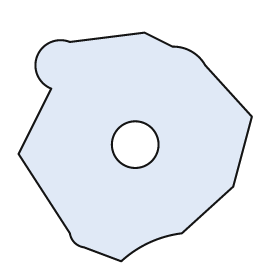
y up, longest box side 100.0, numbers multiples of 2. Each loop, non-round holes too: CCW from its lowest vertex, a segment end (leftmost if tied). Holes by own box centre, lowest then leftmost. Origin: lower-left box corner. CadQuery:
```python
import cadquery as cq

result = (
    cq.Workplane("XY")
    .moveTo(44.0, 0.0)
    .threePointArc((56.0, 8.0), (70.0, 12.0))
    .lineTo(92.0, 32.0)
    .lineTo(100.0, 62.0)
    .lineTo(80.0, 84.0)
    .threePointArc((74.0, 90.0), (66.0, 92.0))
    .lineTo(54.0, 98.0)
    .lineTo(22.0, 94.0)
    .threePointArc((8.0, 88.0), (14.0, 74.0))
    .lineTo(0.0, 46.0)
    .lineTo(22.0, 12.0)
    .threePointArc((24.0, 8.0), (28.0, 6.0))
    .close()
    .moveTo(50.0, 50.0)
    .circle(10.0)
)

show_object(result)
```